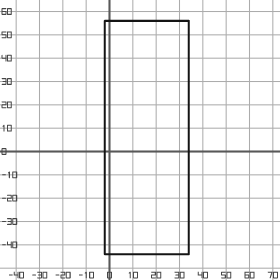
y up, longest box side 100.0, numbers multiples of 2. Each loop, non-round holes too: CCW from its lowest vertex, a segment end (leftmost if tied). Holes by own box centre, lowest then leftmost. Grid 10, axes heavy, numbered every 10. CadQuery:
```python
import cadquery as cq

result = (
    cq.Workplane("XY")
    .moveTo(-2.0, -44.0)
    .lineTo(34.0, -44.0)
    .lineTo(34.0, 56.0)
    .lineTo(-2.0, 56.0)
    .close()
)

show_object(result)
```